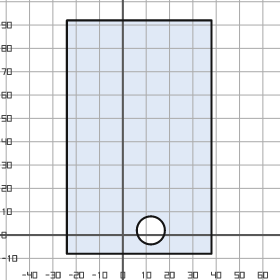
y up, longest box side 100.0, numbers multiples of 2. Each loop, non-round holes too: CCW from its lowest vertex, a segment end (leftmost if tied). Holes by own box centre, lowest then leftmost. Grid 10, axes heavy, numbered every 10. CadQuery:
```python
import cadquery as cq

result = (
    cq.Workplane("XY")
    .moveTo(-24.0, -8.0)
    .lineTo(38.0, -8.0)
    .lineTo(38.0, 92.0)
    .lineTo(-24.0, 92.0)
    .close()
    .moveTo(12.0, 2.0)
    .circle(6.0)
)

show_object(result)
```